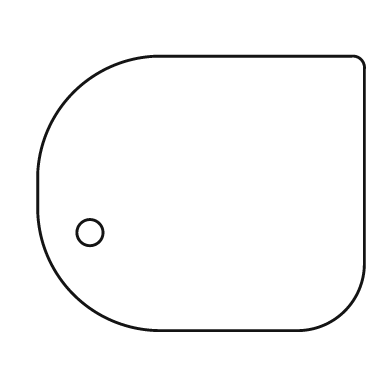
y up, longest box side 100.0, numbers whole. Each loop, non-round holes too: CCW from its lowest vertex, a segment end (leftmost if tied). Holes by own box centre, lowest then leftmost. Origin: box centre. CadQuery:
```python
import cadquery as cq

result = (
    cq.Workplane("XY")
    .moveTo(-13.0, -42.0)
    .lineTo(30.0, -42.0)
    .threePointArc((44.0, -36.0), (50.0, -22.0))
    .lineTo(50.0, 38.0)
    .threePointArc((49.0, 41.0), (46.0, 42.0))
    .lineTo(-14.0, 42.0)
    .threePointArc((-39.0, 31.0), (-50.0, 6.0))
    .lineTo(-50.0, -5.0)
    .threePointArc((-39.0, -31.0), (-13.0, -42.0))
    .close()
    .moveTo(-34.0, -12.0)
    .circle(4.0)
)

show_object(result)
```